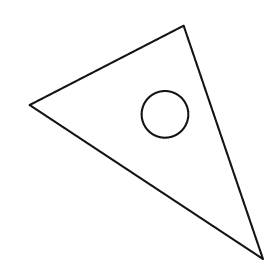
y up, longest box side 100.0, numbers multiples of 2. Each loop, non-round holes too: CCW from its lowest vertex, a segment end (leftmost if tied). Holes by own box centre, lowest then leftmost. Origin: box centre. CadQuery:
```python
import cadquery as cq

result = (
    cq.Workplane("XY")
    .moveTo(50.0, -50.0)
    .lineTo(16.0, 50.0)
    .lineTo(-50.0, 16.0)
    .close()
    .moveTo(8.0, 12.0)
    .circle(10.0)
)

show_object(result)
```